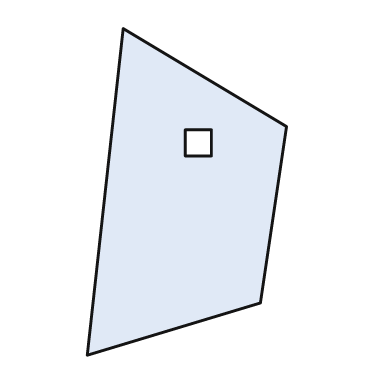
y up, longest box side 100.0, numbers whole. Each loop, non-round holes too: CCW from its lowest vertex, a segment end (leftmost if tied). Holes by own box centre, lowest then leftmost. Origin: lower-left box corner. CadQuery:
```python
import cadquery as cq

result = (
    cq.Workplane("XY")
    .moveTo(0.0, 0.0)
    .lineTo(53.0, 16.0)
    .lineTo(61.0, 70.0)
    .lineTo(11.0, 100.0)
    .close()
    .moveTo(30.0, 61.0)
    .lineTo(38.0, 61.0)
    .lineTo(38.0, 69.0)
    .lineTo(30.0, 69.0)
    .close()
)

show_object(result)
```